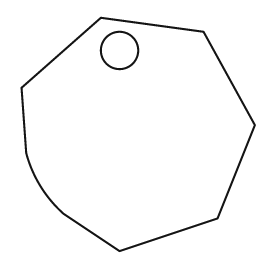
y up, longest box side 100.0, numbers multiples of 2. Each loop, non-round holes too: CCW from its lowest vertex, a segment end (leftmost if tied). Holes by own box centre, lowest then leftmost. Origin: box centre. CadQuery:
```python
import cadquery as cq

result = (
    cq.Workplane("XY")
    .moveTo(-8.0, -50.0)
    .lineTo(34.0, -36.0)
    .lineTo(50.0, 4.0)
    .lineTo(28.0, 44.0)
    .lineTo(-16.0, 50.0)
    .lineTo(-50.0, 20.0)
    .lineTo(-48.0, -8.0)
    .threePointArc((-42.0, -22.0), (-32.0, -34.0))
    .close()
    .moveTo(-8.0, 36.0)
    .circle(8.0)
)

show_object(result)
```